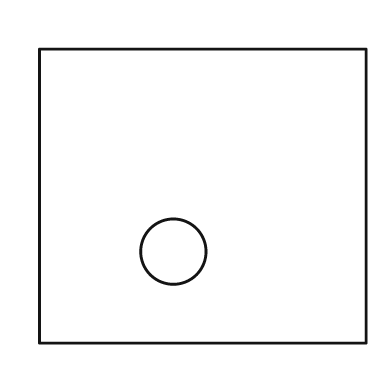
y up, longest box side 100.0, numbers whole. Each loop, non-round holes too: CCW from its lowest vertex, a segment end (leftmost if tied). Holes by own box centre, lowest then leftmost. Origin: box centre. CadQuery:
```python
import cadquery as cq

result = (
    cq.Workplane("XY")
    .moveTo(-50.0, -45.0)
    .lineTo(50.0, -45.0)
    .lineTo(50.0, 45.0)
    .lineTo(-50.0, 45.0)
    .close()
    .moveTo(-9.0, -17.0)
    .circle(10.0)
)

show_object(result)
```